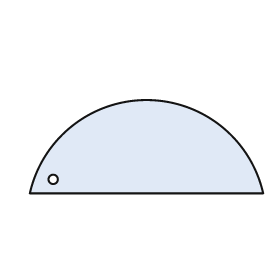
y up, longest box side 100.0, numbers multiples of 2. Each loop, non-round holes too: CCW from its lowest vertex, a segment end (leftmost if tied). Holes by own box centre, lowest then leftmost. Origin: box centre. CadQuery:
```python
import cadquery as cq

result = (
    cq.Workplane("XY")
    .moveTo(-50.0, -20.0)
    .lineTo(50.0, -20.0)
    .threePointArc((0.0, 20.0), (-50.0, -20.0))
    .close()
    .moveTo(-40.0, -14.0)
    .circle(2.0)
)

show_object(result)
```